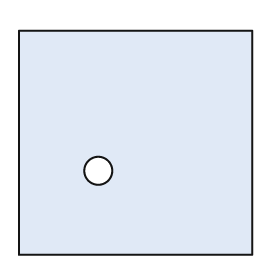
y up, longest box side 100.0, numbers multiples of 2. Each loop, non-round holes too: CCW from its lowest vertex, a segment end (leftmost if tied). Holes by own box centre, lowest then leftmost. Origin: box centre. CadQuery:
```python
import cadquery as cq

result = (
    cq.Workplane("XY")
    .moveTo(-50.0, -48.0)
    .lineTo(50.0, -48.0)
    .lineTo(50.0, 48.0)
    .lineTo(-50.0, 48.0)
    .close()
    .moveTo(-16.0, -12.0)
    .circle(6.0)
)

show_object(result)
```